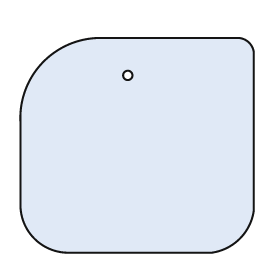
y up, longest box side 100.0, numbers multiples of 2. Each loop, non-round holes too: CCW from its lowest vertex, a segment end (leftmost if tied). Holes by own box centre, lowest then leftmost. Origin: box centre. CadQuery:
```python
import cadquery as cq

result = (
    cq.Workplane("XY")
    .moveTo(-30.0, -46.0)
    .lineTo(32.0, -46.0)
    .threePointArc((44.0, -40.0), (50.0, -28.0))
    .lineTo(50.0, 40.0)
    .threePointArc((48.0, 44.0), (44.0, 46.0))
    .lineTo(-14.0, 46.0)
    .threePointArc((-40.0, 36.0), (-50.0, 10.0))
    .lineTo(-50.0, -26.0)
    .threePointArc((-44.0, -40.0), (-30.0, -46.0))
    .close()
    .moveTo(-4.0, 30.0)
    .circle(2.0)
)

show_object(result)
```